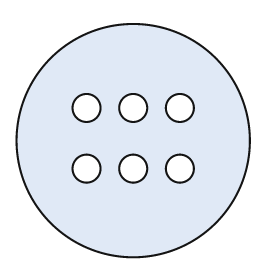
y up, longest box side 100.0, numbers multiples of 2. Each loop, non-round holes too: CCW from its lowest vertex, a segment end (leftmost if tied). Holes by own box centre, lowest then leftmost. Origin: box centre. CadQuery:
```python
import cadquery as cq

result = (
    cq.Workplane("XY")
    .moveTo(0.0, 0.0)
    .circle(50.0)
    .moveTo(-20.0, -12.0)
    .circle(6.0)
    .moveTo(0.0, -12.0)
    .circle(6.0)
    .moveTo(20.0, -12.0)
    .circle(6.0)
    .moveTo(-20.0, 14.0)
    .circle(6.0)
    .moveTo(0.0, 14.0)
    .circle(6.0)
    .moveTo(20.0, 14.0)
    .circle(6.0)
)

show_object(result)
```